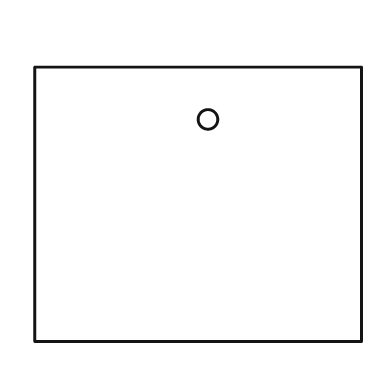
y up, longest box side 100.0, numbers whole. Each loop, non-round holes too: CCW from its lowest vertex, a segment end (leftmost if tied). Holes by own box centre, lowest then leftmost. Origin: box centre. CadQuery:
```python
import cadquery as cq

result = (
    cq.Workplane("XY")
    .moveTo(-50.0, -42.0)
    .lineTo(50.0, -42.0)
    .lineTo(50.0, 42.0)
    .lineTo(-50.0, 42.0)
    .close()
    .moveTo(3.0, 26.0)
    .circle(3.0)
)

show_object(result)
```